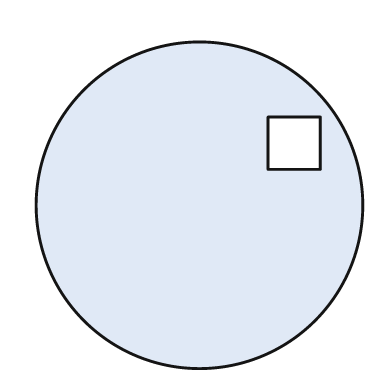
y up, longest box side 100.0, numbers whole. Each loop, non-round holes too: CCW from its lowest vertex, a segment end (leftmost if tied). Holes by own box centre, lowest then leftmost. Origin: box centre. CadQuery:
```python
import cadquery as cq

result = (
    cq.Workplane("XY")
    .moveTo(0.0, 0.0)
    .circle(50.0)
    .moveTo(21.0, 11.0)
    .lineTo(37.0, 11.0)
    .lineTo(37.0, 27.0)
    .lineTo(21.0, 27.0)
    .close()
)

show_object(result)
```